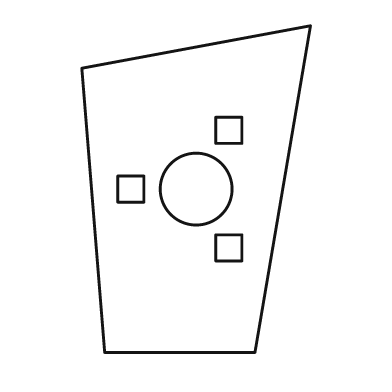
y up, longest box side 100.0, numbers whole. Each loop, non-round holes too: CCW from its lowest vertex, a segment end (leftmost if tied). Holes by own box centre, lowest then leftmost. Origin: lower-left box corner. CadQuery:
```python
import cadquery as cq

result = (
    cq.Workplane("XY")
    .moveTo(7.0, 0.0)
    .lineTo(53.0, 0.0)
    .lineTo(70.0, 100.0)
    .lineTo(0.0, 87.0)
    .close()
    .moveTo(41.0, 28.0)
    .lineTo(49.0, 28.0)
    .lineTo(49.0, 36.0)
    .lineTo(41.0, 36.0)
    .close()
    .moveTo(11.0, 46.0)
    .lineTo(19.0, 46.0)
    .lineTo(19.0, 54.0)
    .lineTo(11.0, 54.0)
    .close()
    .moveTo(35.0, 50.0)
    .circle(11.0)
    .moveTo(41.0, 64.0)
    .lineTo(49.0, 64.0)
    .lineTo(49.0, 72.0)
    .lineTo(41.0, 72.0)
    .close()
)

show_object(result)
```